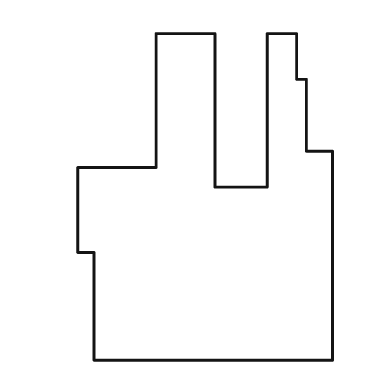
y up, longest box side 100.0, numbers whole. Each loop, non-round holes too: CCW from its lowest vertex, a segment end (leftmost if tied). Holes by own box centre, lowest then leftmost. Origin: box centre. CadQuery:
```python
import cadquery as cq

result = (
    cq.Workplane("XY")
    .moveTo(-34.0, -50.0)
    .lineTo(39.0, -50.0)
    .lineTo(39.0, 14.0)
    .lineTo(31.0, 14.0)
    .lineTo(31.0, 36.0)
    .lineTo(28.0, 36.0)
    .lineTo(28.0, 50.0)
    .lineTo(19.0, 50.0)
    .lineTo(19.0, 3.0)
    .lineTo(3.0, 3.0)
    .lineTo(3.0, 50.0)
    .lineTo(-15.0, 50.0)
    .lineTo(-15.0, 9.0)
    .lineTo(-39.0, 9.0)
    .lineTo(-39.0, -17.0)
    .lineTo(-34.0, -17.0)
    .close()
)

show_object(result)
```